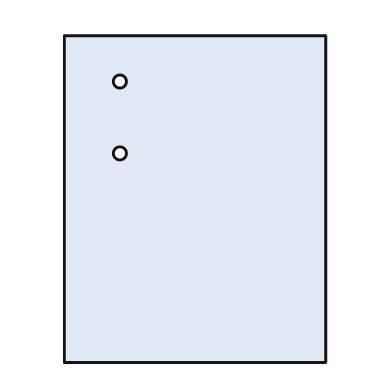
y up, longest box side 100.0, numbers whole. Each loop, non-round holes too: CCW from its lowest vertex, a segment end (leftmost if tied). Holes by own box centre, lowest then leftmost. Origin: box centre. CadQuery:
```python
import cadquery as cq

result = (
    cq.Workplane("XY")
    .moveTo(-40.0, -50.0)
    .lineTo(40.0, -50.0)
    .lineTo(40.0, 50.0)
    .lineTo(-40.0, 50.0)
    .close()
    .moveTo(-23.0, 14.0)
    .circle(2.0)
    .moveTo(-23.0, 36.0)
    .circle(2.0)
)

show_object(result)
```